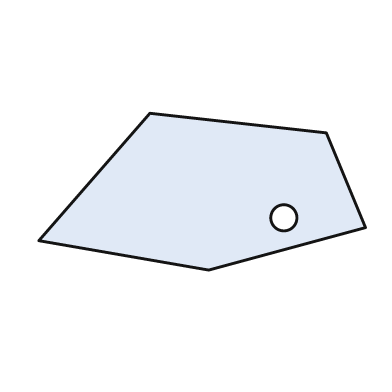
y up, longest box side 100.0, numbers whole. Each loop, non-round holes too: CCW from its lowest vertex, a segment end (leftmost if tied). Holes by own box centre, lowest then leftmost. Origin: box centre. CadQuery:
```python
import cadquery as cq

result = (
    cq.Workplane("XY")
    .moveTo(2.0, -24.0)
    .lineTo(50.0, -11.0)
    .lineTo(38.0, 18.0)
    .lineTo(-16.0, 24.0)
    .lineTo(-50.0, -15.0)
    .close()
    .moveTo(25.0, -8.0)
    .circle(4.0)
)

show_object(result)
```